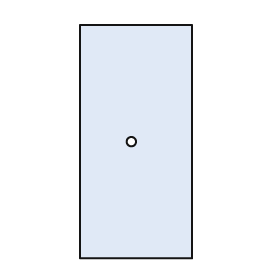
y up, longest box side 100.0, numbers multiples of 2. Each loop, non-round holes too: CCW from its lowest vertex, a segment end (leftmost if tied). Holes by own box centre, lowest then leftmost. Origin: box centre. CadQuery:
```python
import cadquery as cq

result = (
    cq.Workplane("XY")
    .moveTo(-24.0, -50.0)
    .lineTo(24.0, -50.0)
    .lineTo(24.0, 50.0)
    .lineTo(-24.0, 50.0)
    .close()
    .moveTo(-2.0, 0.0)
    .circle(2.0)
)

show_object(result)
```